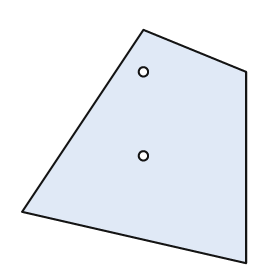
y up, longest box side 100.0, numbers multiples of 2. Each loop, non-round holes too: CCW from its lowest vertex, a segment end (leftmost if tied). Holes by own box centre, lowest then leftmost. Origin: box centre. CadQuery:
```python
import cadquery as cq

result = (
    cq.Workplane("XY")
    .moveTo(48.0, -50.0)
    .lineTo(48.0, 32.0)
    .lineTo(4.0, 50.0)
    .lineTo(-48.0, -28.0)
    .close()
    .moveTo(4.0, -4.0)
    .circle(2.0)
    .moveTo(4.0, 32.0)
    .circle(2.0)
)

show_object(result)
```